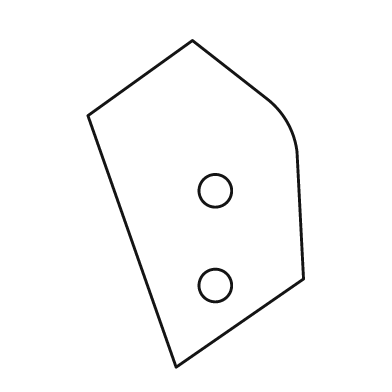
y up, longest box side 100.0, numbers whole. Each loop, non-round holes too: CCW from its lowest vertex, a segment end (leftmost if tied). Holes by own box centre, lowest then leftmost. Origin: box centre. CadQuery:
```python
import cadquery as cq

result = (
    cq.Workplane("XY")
    .moveTo(-6.0, -50.0)
    .lineTo(33.0, -23.0)
    .lineTo(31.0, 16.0)
    .threePointArc((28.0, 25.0), (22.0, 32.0))
    .lineTo(-1.0, 50.0)
    .lineTo(-33.0, 27.0)
    .close()
    .moveTo(6.0, -25.0)
    .circle(5.0)
    .moveTo(6.0, 4.0)
    .circle(5.0)
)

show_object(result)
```